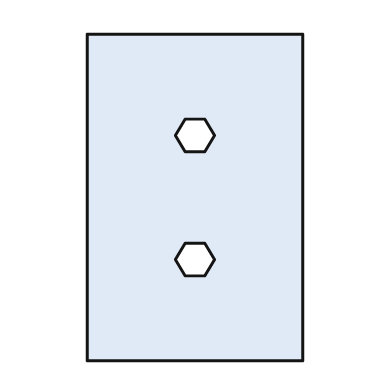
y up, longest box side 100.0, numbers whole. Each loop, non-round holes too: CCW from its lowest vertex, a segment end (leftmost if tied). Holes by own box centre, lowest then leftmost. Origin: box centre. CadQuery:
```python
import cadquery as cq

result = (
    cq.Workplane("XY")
    .moveTo(-33.0, -50.0)
    .lineTo(33.0, -50.0)
    .lineTo(33.0, 50.0)
    .lineTo(-33.0, 50.0)
    .close()
    .moveTo(-3.0, -24.0)
    .lineTo(3.0, -24.0)
    .lineTo(6.0, -19.0)
    .lineTo(3.0, -14.0)
    .lineTo(-3.0, -14.0)
    .lineTo(-6.0, -19.0)
    .close()
    .moveTo(-3.0, 14.0)
    .lineTo(3.0, 14.0)
    .lineTo(6.0, 19.0)
    .lineTo(3.0, 24.0)
    .lineTo(-3.0, 24.0)
    .lineTo(-6.0, 19.0)
    .close()
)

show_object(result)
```